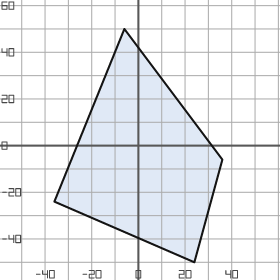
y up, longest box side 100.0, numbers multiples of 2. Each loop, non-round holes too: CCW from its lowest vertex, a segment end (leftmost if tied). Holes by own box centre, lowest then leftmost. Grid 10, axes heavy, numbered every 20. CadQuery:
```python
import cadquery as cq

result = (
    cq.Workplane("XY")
    .moveTo(24.0, -50.0)
    .lineTo(36.0, -6.0)
    .lineTo(-6.0, 50.0)
    .lineTo(-36.0, -24.0)
    .close()
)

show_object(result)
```